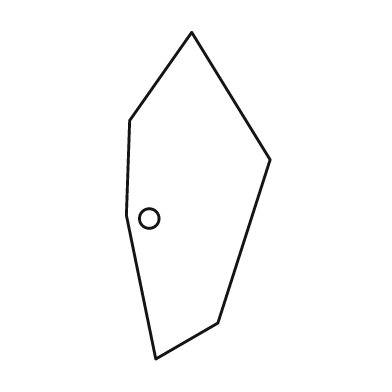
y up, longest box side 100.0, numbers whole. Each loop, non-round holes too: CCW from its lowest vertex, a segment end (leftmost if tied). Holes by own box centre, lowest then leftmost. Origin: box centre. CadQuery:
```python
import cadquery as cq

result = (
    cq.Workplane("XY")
    .moveTo(-13.0, -50.0)
    .lineTo(6.0, -39.0)
    .lineTo(22.0, 11.0)
    .lineTo(-2.0, 50.0)
    .lineTo(-21.0, 23.0)
    .lineTo(-22.0, -6.0)
    .close()
    .moveTo(-15.0, -7.0)
    .circle(3.0)
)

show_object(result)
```